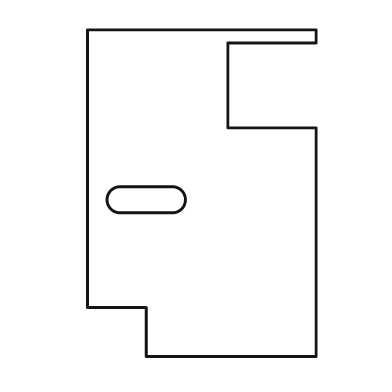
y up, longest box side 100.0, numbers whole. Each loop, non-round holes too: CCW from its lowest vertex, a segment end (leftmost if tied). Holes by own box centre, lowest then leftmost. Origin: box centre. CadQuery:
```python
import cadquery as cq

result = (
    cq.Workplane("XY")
    .moveTo(-17.0, -50.0)
    .lineTo(35.0, -50.0)
    .lineTo(35.0, 20.0)
    .lineTo(8.0, 20.0)
    .lineTo(8.0, 46.0)
    .lineTo(35.0, 46.0)
    .lineTo(35.0, 50.0)
    .lineTo(-35.0, 50.0)
    .lineTo(-35.0, -35.0)
    .lineTo(-17.0, -35.0)
    .close()
    .moveTo(-25.0, -6.0)
    .lineTo(-9.0, -6.0)
    .threePointArc((-5.0, -2.0), (-9.0, 2.0))
    .lineTo(-25.0, 2.0)
    .threePointArc((-29.0, -2.0), (-25.0, -6.0))
    .close()
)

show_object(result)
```